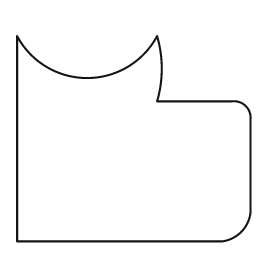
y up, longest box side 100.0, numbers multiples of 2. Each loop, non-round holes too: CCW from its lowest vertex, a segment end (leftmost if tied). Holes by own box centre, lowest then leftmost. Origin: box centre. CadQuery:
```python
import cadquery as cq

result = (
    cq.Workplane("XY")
    .moveTo(-50.0, -44.0)
    .lineTo(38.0, -44.0)
    .threePointArc((46.0, -40.0), (50.0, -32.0))
    .lineTo(50.0, 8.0)
    .threePointArc((48.0, 14.0), (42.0, 16.0))
    .lineTo(10.0, 16.0)
    .threePointArc((12.0, 30.0), (10.0, 44.0))
    .threePointArc((-20.0, 26.0), (-50.0, 44.0))
    .close()
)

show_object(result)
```